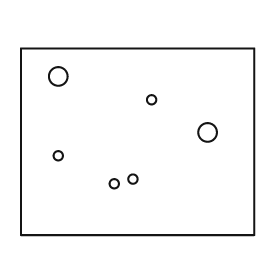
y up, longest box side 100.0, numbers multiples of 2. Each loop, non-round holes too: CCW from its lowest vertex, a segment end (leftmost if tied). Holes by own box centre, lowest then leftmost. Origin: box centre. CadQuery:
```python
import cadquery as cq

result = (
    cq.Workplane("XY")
    .moveTo(-50.0, -40.0)
    .lineTo(50.0, -40.0)
    .lineTo(50.0, 40.0)
    .lineTo(-50.0, 40.0)
    .close()
    .moveTo(-10.0, -18.0)
    .circle(2.0)
    .moveTo(-2.0, -16.0)
    .circle(2.0)
    .moveTo(-34.0, -6.0)
    .circle(2.0)
    .moveTo(30.0, 4.0)
    .circle(4.0)
    .moveTo(6.0, 18.0)
    .circle(2.0)
    .moveTo(-34.0, 28.0)
    .circle(4.0)
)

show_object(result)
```